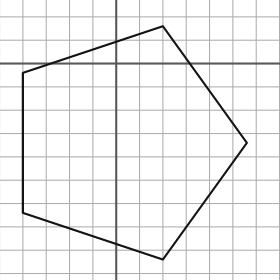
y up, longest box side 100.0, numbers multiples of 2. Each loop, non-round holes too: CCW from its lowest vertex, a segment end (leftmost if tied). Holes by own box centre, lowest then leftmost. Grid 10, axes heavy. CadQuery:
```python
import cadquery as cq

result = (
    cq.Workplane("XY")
    .moveTo(20.0, -84.0)
    .lineTo(56.0, -34.0)
    .lineTo(20.0, 16.0)
    .lineTo(-40.0, -4.0)
    .lineTo(-40.0, -64.0)
    .close()
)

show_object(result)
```